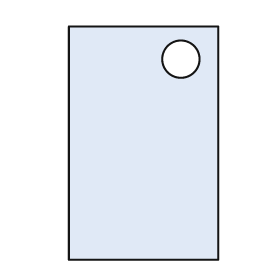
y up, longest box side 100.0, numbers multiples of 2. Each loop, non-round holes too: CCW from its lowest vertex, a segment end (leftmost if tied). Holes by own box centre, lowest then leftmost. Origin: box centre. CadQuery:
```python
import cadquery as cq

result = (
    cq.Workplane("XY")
    .moveTo(-32.0, -50.0)
    .lineTo(32.0, -50.0)
    .lineTo(32.0, 50.0)
    .lineTo(-32.0, 50.0)
    .close()
    .moveTo(16.0, 36.0)
    .circle(8.0)
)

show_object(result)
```